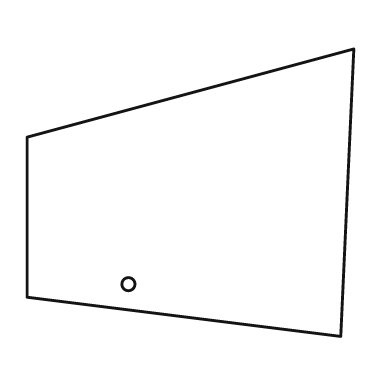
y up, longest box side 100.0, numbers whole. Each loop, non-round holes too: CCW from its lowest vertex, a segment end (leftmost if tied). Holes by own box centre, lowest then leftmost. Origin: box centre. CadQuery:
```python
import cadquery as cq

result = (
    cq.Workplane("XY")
    .moveTo(46.0, -44.0)
    .lineTo(50.0, 44.0)
    .lineTo(-50.0, 17.0)
    .lineTo(-50.0, -32.0)
    .close()
    .moveTo(-19.0, -28.0)
    .circle(2.0)
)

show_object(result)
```